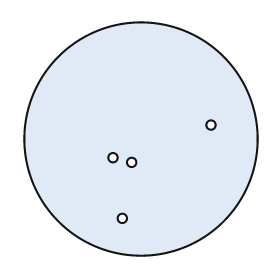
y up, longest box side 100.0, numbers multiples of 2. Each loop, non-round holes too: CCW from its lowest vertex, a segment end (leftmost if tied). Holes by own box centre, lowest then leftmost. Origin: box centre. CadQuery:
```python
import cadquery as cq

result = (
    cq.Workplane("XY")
    .moveTo(0.0, 0.0)
    .circle(50.0)
    .moveTo(-8.0, -34.0)
    .circle(2.0)
    .moveTo(-4.0, -10.0)
    .circle(2.0)
    .moveTo(-12.0, -8.0)
    .circle(2.0)
    .moveTo(30.0, 6.0)
    .circle(2.0)
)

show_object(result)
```